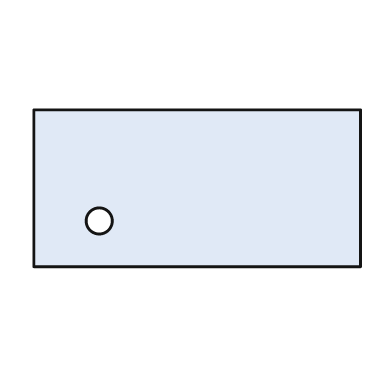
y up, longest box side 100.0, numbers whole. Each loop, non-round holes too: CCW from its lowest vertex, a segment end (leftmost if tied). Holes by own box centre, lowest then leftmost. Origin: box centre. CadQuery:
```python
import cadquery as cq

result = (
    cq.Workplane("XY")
    .moveTo(-50.0, -24.0)
    .lineTo(50.0, -24.0)
    .lineTo(50.0, 24.0)
    .lineTo(-50.0, 24.0)
    .close()
    .moveTo(-30.0, -10.0)
    .circle(4.0)
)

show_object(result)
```